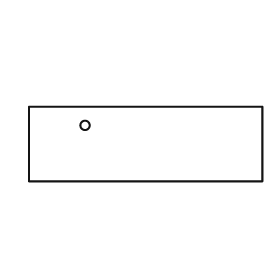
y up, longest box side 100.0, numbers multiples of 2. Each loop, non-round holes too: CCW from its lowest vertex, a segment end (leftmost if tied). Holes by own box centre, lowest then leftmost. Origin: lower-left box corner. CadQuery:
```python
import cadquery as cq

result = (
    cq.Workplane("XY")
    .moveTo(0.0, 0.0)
    .lineTo(100.0, 0.0)
    .lineTo(100.0, 32.0)
    .lineTo(0.0, 32.0)
    .close()
    .moveTo(24.0, 24.0)
    .circle(2.0)
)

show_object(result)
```